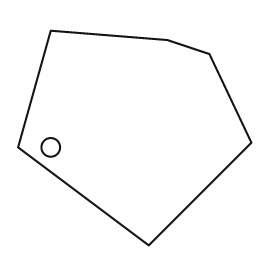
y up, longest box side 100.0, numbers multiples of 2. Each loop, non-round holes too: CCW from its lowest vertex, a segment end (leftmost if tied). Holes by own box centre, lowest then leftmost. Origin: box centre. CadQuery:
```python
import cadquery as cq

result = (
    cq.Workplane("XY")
    .moveTo(6.0, -46.0)
    .lineTo(50.0, -2.0)
    .lineTo(32.0, 36.0)
    .lineTo(14.0, 42.0)
    .lineTo(-36.0, 46.0)
    .lineTo(-50.0, -4.0)
    .close()
    .moveTo(-36.0, -4.0)
    .circle(4.0)
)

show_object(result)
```